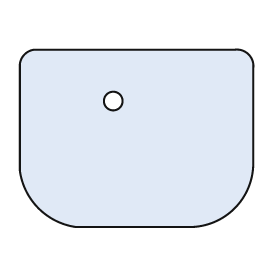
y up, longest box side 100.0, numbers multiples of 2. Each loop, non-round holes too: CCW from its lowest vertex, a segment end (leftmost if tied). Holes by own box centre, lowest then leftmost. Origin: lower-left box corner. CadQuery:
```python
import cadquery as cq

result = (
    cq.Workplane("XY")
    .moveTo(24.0, 0.0)
    .lineTo(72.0, 0.0)
    .threePointArc((92.0, 8.0), (100.0, 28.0))
    .lineTo(100.0, 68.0)
    .threePointArc((98.0, 74.0), (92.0, 76.0))
    .lineTo(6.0, 76.0)
    .threePointArc((2.0, 74.0), (0.0, 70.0))
    .lineTo(0.0, 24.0)
    .threePointArc((8.0, 8.0), (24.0, 0.0))
    .close()
    .moveTo(40.0, 54.0)
    .circle(4.0)
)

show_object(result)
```